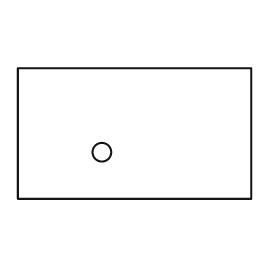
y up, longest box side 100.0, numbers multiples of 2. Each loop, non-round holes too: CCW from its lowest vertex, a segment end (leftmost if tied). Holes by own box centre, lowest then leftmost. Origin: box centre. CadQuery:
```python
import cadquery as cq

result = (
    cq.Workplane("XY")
    .moveTo(-50.0, -28.0)
    .lineTo(50.0, -28.0)
    .lineTo(50.0, 28.0)
    .lineTo(-50.0, 28.0)
    .close()
    .moveTo(-14.0, -8.0)
    .circle(4.0)
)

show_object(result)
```